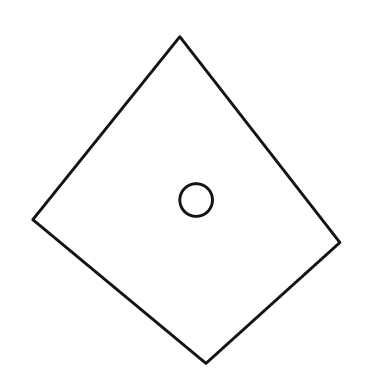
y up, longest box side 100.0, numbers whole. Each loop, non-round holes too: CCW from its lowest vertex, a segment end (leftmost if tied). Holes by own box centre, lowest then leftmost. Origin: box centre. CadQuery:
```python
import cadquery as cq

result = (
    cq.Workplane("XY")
    .moveTo(6.0, -50.0)
    .lineTo(47.0, -13.0)
    .lineTo(-2.0, 50.0)
    .lineTo(-47.0, -6.0)
    .close()
    .moveTo(3.0, 0.0)
    .circle(5.0)
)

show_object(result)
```